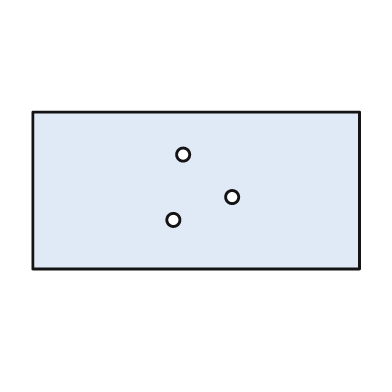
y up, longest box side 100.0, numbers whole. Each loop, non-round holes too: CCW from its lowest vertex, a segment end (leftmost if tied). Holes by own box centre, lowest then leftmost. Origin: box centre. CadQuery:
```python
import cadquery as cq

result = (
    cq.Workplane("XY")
    .moveTo(-50.0, -24.0)
    .lineTo(50.0, -24.0)
    .lineTo(50.0, 24.0)
    .lineTo(-50.0, 24.0)
    .close()
    .moveTo(-7.0, -9.0)
    .circle(2.0)
    .moveTo(11.0, -2.0)
    .circle(2.0)
    .moveTo(-4.0, 11.0)
    .circle(2.0)
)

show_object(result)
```